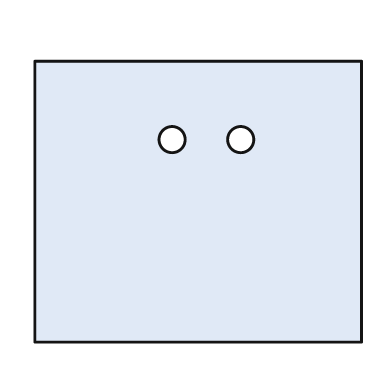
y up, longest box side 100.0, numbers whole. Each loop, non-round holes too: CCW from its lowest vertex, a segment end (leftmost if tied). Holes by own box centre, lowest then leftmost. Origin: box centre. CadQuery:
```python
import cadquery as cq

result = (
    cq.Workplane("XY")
    .moveTo(-50.0, -43.0)
    .lineTo(50.0, -43.0)
    .lineTo(50.0, 43.0)
    .lineTo(-50.0, 43.0)
    .close()
    .moveTo(-8.0, 19.0)
    .circle(4.0)
    .moveTo(13.0, 19.0)
    .circle(4.0)
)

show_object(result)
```